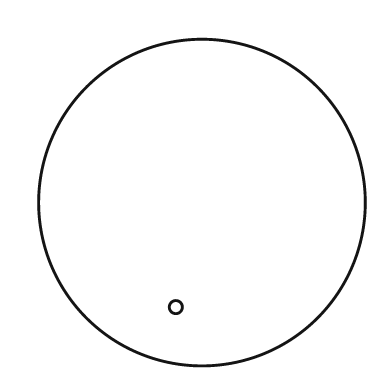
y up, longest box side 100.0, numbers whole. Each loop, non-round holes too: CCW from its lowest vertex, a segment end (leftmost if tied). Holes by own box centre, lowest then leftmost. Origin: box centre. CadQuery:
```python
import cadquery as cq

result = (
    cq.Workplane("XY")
    .moveTo(0.0, 0.0)
    .circle(50.0)
    .moveTo(-8.0, -32.0)
    .circle(2.0)
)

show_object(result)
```